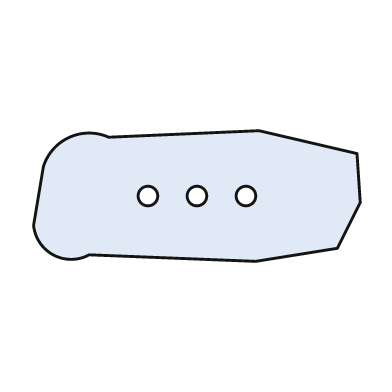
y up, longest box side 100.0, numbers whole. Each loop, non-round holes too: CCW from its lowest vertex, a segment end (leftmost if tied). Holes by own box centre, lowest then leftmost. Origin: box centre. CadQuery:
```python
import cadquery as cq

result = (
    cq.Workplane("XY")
    .moveTo(18.0, -20.0)
    .lineTo(43.0, -16.0)
    .lineTo(50.0, -2.0)
    .lineTo(49.0, 13.0)
    .lineTo(19.0, 20.0)
    .lineTo(-27.0, 18.0)
    .threePointArc((-39.0, 18.0), (-47.0, 9.0))
    .lineTo(-50.0, -9.0)
    .threePointArc((-44.0, -18.0), (-33.0, -18.0))
    .close()
    .moveTo(-15.0, 0.0)
    .circle(3.0)
    .moveTo(0.0, 0.0)
    .circle(3.0)
    .moveTo(15.0, 0.0)
    .circle(3.0)
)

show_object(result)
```